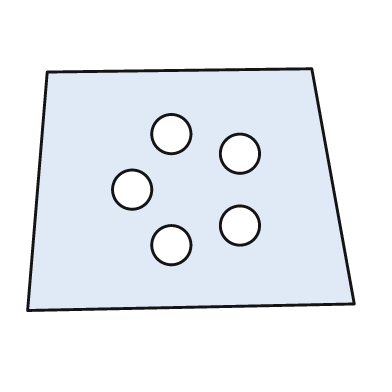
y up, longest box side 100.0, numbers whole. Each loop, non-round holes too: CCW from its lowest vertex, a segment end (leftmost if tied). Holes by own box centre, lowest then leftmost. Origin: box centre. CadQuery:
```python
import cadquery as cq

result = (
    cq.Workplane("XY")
    .moveTo(-50.0, -37.0)
    .lineTo(50.0, -35.0)
    .lineTo(37.0, 37.0)
    .lineTo(-44.0, 36.0)
    .close()
    .moveTo(-6.0, -17.0)
    .circle(6.0)
    .moveTo(15.0, -11.0)
    .circle(6.0)
    .moveTo(-18.0, 0.0)
    .circle(6.0)
    .moveTo(15.0, 11.0)
    .circle(6.0)
    .moveTo(-6.0, 17.0)
    .circle(6.0)
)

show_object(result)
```